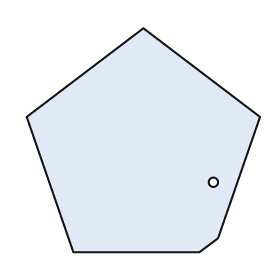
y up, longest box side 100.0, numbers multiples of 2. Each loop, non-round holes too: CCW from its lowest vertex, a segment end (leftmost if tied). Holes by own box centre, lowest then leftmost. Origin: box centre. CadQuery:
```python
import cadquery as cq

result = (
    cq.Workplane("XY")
    .moveTo(-30.0, -48.0)
    .lineTo(24.0, -48.0)
    .lineTo(32.0, -42.0)
    .lineTo(50.0, 10.0)
    .lineTo(0.0, 48.0)
    .lineTo(-50.0, 10.0)
    .close()
    .moveTo(30.0, -18.0)
    .circle(2.0)
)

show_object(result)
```